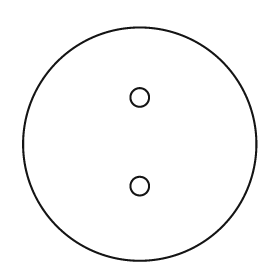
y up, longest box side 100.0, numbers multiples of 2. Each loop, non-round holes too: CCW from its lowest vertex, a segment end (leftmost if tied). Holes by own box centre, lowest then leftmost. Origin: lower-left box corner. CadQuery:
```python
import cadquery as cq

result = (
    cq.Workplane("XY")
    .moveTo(50.0, 50.0)
    .circle(50.0)
    .moveTo(50.0, 32.0)
    .circle(4.0)
    .moveTo(50.0, 70.0)
    .circle(4.0)
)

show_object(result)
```